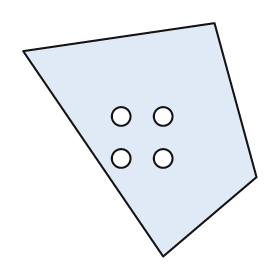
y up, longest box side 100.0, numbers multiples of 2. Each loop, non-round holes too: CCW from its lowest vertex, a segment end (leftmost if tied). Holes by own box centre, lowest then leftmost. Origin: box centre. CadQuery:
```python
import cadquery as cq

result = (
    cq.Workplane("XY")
    .moveTo(10.0, -50.0)
    .lineTo(50.0, -16.0)
    .lineTo(32.0, 50.0)
    .lineTo(-50.0, 38.0)
    .close()
    .moveTo(-8.0, -8.0)
    .circle(4.0)
    .moveTo(10.0, -8.0)
    .circle(4.0)
    .moveTo(-8.0, 10.0)
    .circle(4.0)
    .moveTo(10.0, 10.0)
    .circle(4.0)
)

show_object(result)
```